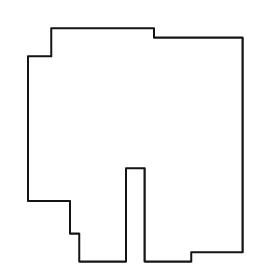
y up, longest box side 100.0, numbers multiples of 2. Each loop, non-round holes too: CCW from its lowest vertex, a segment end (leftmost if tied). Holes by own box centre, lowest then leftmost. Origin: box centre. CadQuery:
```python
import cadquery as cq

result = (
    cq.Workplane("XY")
    .moveTo(-24.0, -50.0)
    .lineTo(-4.0, -50.0)
    .lineTo(-4.0, -10.0)
    .lineTo(4.0, -10.0)
    .lineTo(4.0, -50.0)
    .lineTo(24.0, -50.0)
    .lineTo(24.0, -46.0)
    .lineTo(46.0, -46.0)
    .lineTo(46.0, 46.0)
    .lineTo(8.0, 46.0)
    .lineTo(8.0, 50.0)
    .lineTo(-36.0, 50.0)
    .lineTo(-36.0, 38.0)
    .lineTo(-46.0, 38.0)
    .lineTo(-46.0, -24.0)
    .lineTo(-28.0, -24.0)
    .lineTo(-28.0, -38.0)
    .lineTo(-24.0, -38.0)
    .close()
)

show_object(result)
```